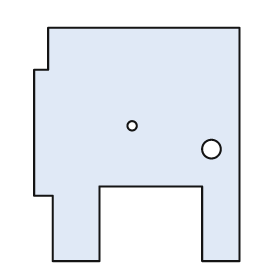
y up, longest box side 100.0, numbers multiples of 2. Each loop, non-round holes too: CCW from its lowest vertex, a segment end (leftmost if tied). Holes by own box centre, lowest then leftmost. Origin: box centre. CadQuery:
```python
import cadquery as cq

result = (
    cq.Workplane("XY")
    .moveTo(-36.0, -50.0)
    .lineTo(-16.0, -50.0)
    .lineTo(-16.0, -18.0)
    .lineTo(28.0, -18.0)
    .lineTo(28.0, -50.0)
    .lineTo(44.0, -50.0)
    .lineTo(44.0, 50.0)
    .lineTo(-38.0, 50.0)
    .lineTo(-38.0, 32.0)
    .lineTo(-44.0, 32.0)
    .lineTo(-44.0, -22.0)
    .lineTo(-36.0, -22.0)
    .close()
    .moveTo(32.0, -2.0)
    .circle(4.0)
    .moveTo(-2.0, 8.0)
    .circle(2.0)
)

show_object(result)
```